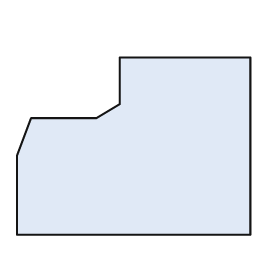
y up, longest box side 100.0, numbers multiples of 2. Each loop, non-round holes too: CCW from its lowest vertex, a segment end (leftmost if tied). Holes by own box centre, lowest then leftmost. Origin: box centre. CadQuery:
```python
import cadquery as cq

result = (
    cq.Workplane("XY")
    .moveTo(-50.0, -38.0)
    .lineTo(50.0, -38.0)
    .lineTo(50.0, 38.0)
    .lineTo(-6.0, 38.0)
    .lineTo(-6.0, 18.0)
    .lineTo(-16.0, 12.0)
    .lineTo(-44.0, 12.0)
    .lineTo(-50.0, -4.0)
    .close()
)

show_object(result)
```